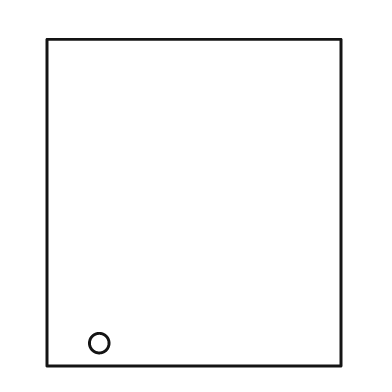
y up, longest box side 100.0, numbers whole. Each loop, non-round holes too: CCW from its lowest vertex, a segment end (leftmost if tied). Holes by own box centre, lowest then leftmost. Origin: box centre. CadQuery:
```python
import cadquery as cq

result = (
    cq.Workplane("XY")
    .moveTo(-45.0, -50.0)
    .lineTo(45.0, -50.0)
    .lineTo(45.0, 50.0)
    .lineTo(-45.0, 50.0)
    .close()
    .moveTo(-29.0, -43.0)
    .circle(3.0)
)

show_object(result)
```